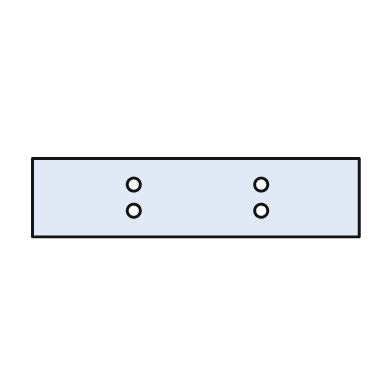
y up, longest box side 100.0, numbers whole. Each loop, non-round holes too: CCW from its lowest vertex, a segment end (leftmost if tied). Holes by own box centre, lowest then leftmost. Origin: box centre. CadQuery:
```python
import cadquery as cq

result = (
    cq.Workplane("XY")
    .moveTo(-50.0, -12.0)
    .lineTo(50.0, -12.0)
    .lineTo(50.0, 12.0)
    .lineTo(-50.0, 12.0)
    .close()
    .moveTo(-19.0, -4.0)
    .circle(2.0)
    .moveTo(20.0, -4.0)
    .circle(2.0)
    .moveTo(-19.0, 4.0)
    .circle(2.0)
    .moveTo(20.0, 4.0)
    .circle(2.0)
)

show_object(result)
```